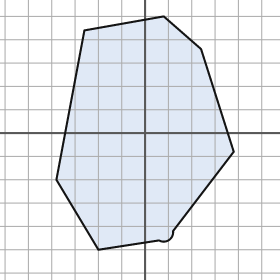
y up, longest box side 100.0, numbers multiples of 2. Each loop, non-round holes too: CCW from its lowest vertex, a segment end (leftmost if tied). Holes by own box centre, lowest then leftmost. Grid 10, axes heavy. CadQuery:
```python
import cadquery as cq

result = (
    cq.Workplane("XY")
    .moveTo(-20.0, -50.0)
    .lineTo(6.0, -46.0)
    .threePointArc((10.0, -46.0), (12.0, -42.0))
    .lineTo(38.0, -8.0)
    .lineTo(24.0, 36.0)
    .lineTo(8.0, 50.0)
    .lineTo(-26.0, 44.0)
    .lineTo(-38.0, -20.0)
    .close()
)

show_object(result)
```